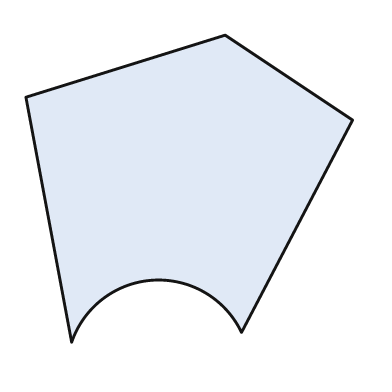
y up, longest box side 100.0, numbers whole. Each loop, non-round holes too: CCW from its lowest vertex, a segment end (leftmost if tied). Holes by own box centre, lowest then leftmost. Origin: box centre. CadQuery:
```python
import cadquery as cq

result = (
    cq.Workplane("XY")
    .moveTo(-36.0, -47.0)
    .threePointArc((-11.0, -28.0), (16.0, -44.0))
    .lineTo(50.0, 21.0)
    .lineTo(11.0, 47.0)
    .lineTo(-50.0, 28.0)
    .close()
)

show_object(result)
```